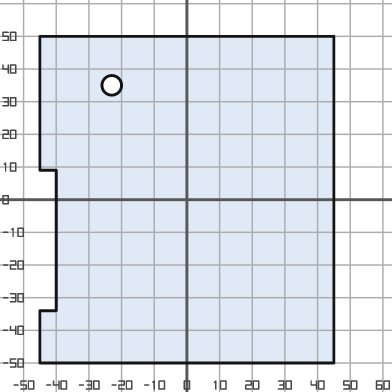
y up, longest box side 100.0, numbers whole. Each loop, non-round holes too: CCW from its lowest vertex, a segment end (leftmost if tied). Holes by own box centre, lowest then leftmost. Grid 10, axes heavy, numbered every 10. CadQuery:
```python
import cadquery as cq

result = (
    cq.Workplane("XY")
    .moveTo(-45.0, -50.0)
    .lineTo(45.0, -50.0)
    .lineTo(45.0, 50.0)
    .lineTo(-45.0, 50.0)
    .lineTo(-45.0, 9.0)
    .lineTo(-40.0, 9.0)
    .lineTo(-40.0, -34.0)
    .lineTo(-45.0, -34.0)
    .close()
    .moveTo(-23.0, 35.0)
    .circle(3.0)
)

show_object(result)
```